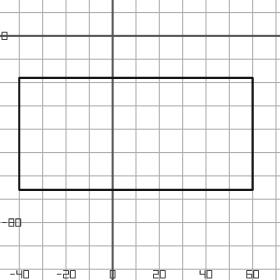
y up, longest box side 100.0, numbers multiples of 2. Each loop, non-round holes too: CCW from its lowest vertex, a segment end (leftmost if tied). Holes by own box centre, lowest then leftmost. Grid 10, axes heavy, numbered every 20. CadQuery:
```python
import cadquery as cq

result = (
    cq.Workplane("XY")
    .moveTo(-40.0, -66.0)
    .lineTo(60.0, -66.0)
    .lineTo(60.0, -18.0)
    .lineTo(-40.0, -18.0)
    .close()
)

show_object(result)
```